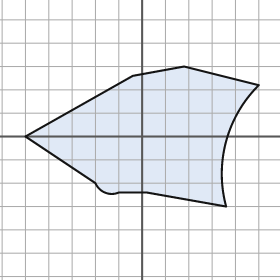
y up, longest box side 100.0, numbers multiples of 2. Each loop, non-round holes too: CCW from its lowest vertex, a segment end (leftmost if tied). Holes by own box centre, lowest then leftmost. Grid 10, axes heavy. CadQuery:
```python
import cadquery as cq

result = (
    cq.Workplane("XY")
    .moveTo(36.0, -30.0)
    .threePointArc((36.0, -2.0), (50.0, 22.0))
    .lineTo(18.0, 30.0)
    .lineTo(-4.0, 26.0)
    .lineTo(-50.0, 0.0)
    .lineTo(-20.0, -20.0)
    .threePointArc((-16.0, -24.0), (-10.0, -24.0))
    .lineTo(2.0, -24.0)
    .close()
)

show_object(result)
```